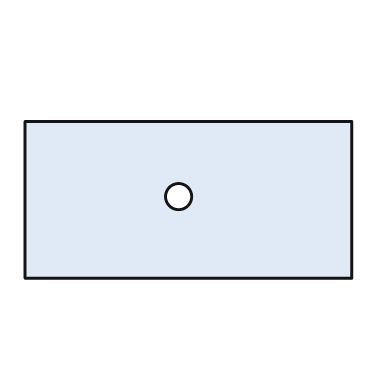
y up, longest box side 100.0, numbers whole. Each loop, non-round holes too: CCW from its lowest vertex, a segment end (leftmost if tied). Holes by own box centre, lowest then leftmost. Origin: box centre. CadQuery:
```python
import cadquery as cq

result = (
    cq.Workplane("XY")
    .moveTo(-50.0, -24.0)
    .lineTo(50.0, -24.0)
    .lineTo(50.0, 24.0)
    .lineTo(-50.0, 24.0)
    .close()
    .moveTo(-3.0, 1.0)
    .circle(4.0)
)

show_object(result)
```